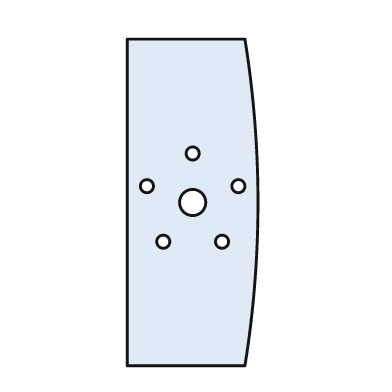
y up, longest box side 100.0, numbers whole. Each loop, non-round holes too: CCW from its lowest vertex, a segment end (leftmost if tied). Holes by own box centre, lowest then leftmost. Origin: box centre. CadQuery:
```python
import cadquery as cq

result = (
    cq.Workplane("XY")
    .moveTo(-20.0, -50.0)
    .lineTo(16.0, -50.0)
    .threePointArc((20.0, 0.0), (16.0, 50.0))
    .lineTo(-20.0, 50.0)
    .close()
    .moveTo(-9.0, -12.0)
    .circle(2.0)
    .moveTo(9.0, -12.0)
    .circle(2.0)
    .moveTo(0.0, 0.0)
    .circle(4.0)
    .moveTo(-14.0, 5.0)
    .circle(2.0)
    .moveTo(14.0, 5.0)
    .circle(2.0)
    .moveTo(0.0, 15.0)
    .circle(2.0)
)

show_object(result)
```